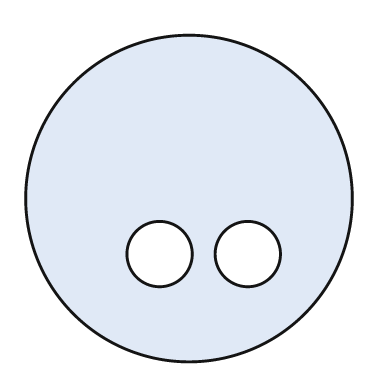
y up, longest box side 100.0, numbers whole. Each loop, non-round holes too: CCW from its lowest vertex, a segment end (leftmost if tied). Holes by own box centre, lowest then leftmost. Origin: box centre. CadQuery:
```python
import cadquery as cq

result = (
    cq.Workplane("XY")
    .moveTo(0.0, 0.0)
    .circle(50.0)
    .moveTo(-9.0, -17.0)
    .circle(10.0)
    .moveTo(18.0, -17.0)
    .circle(10.0)
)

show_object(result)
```